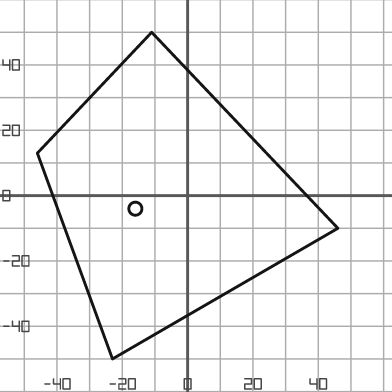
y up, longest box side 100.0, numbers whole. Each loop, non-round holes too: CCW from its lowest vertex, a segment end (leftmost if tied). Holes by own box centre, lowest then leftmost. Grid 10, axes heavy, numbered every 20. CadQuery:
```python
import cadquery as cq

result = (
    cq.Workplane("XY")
    .moveTo(-23.0, -50.0)
    .lineTo(46.0, -10.0)
    .lineTo(-11.0, 50.0)
    .lineTo(-46.0, 13.0)
    .close()
    .moveTo(-16.0, -4.0)
    .circle(2.0)
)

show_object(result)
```